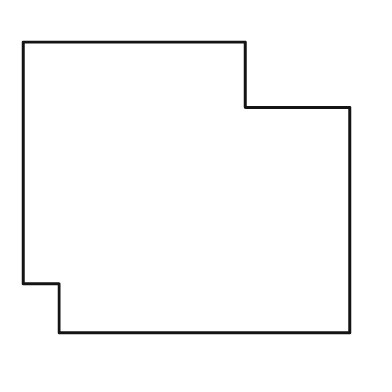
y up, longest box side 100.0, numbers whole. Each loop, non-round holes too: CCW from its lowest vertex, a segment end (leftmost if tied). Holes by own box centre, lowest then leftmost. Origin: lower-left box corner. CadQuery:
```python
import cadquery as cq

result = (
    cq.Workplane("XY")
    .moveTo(11.0, 0.0)
    .lineTo(100.0, 0.0)
    .lineTo(100.0, 69.0)
    .lineTo(68.0, 69.0)
    .lineTo(68.0, 89.0)
    .lineTo(0.0, 89.0)
    .lineTo(0.0, 15.0)
    .lineTo(11.0, 15.0)
    .close()
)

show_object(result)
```